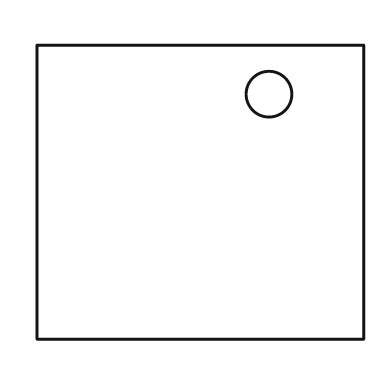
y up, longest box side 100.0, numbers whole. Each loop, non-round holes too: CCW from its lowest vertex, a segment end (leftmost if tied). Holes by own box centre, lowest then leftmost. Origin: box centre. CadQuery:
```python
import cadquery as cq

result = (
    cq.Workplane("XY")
    .moveTo(-50.0, -45.0)
    .lineTo(50.0, -45.0)
    .lineTo(50.0, 45.0)
    .lineTo(-50.0, 45.0)
    .close()
    .moveTo(21.0, 30.0)
    .circle(7.0)
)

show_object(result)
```